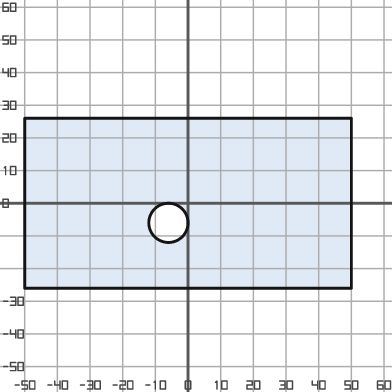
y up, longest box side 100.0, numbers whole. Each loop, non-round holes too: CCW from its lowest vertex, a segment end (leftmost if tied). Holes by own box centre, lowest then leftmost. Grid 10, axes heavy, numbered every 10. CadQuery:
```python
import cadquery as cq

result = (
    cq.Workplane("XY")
    .moveTo(-50.0, -26.0)
    .lineTo(50.0, -26.0)
    .lineTo(50.0, 26.0)
    .lineTo(-50.0, 26.0)
    .close()
    .moveTo(-6.0, -6.0)
    .circle(6.0)
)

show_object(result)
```